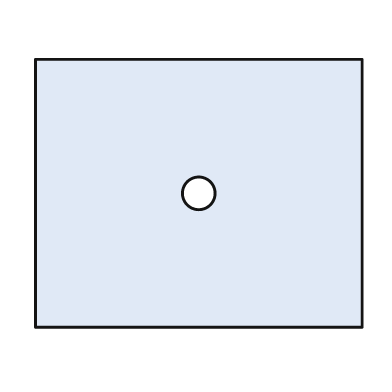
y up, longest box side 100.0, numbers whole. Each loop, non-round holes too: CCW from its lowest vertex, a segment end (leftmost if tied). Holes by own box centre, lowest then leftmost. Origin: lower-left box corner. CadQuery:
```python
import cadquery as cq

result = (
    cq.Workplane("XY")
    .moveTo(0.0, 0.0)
    .lineTo(100.0, 0.0)
    .lineTo(100.0, 82.0)
    .lineTo(0.0, 82.0)
    .close()
    .moveTo(50.0, 41.0)
    .circle(5.0)
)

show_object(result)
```